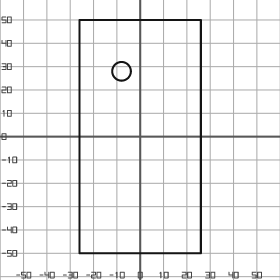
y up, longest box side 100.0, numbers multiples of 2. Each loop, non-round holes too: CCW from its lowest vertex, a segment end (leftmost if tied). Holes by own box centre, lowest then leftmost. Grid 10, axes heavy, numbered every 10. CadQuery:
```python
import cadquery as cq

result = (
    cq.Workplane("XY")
    .moveTo(-26.0, -50.0)
    .lineTo(26.0, -50.0)
    .lineTo(26.0, 50.0)
    .lineTo(-26.0, 50.0)
    .close()
    .moveTo(-8.0, 28.0)
    .circle(4.0)
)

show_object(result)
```